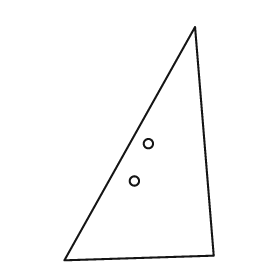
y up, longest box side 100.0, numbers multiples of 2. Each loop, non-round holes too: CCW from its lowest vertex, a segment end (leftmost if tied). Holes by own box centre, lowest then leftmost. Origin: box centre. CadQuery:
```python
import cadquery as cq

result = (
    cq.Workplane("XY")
    .moveTo(-32.0, -50.0)
    .lineTo(32.0, -48.0)
    .lineTo(24.0, 50.0)
    .close()
    .moveTo(-2.0, -16.0)
    .circle(2.0)
    .moveTo(4.0, 0.0)
    .circle(2.0)
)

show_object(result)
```